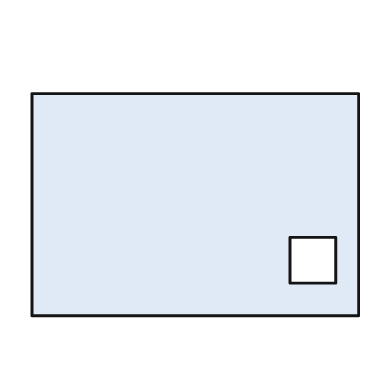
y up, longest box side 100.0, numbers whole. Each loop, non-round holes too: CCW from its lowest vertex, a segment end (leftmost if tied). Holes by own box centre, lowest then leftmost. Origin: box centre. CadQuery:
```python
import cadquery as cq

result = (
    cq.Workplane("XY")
    .moveTo(-50.0, -34.0)
    .lineTo(50.0, -34.0)
    .lineTo(50.0, 34.0)
    .lineTo(-50.0, 34.0)
    .close()
    .moveTo(29.0, -24.0)
    .lineTo(43.0, -24.0)
    .lineTo(43.0, -10.0)
    .lineTo(29.0, -10.0)
    .close()
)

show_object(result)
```